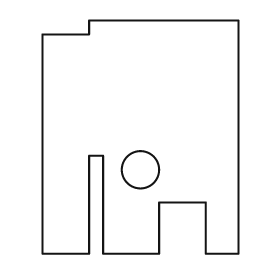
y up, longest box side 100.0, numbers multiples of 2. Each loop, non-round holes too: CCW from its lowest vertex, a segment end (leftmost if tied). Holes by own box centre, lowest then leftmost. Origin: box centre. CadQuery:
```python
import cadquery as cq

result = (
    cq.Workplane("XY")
    .moveTo(-42.0, -50.0)
    .lineTo(-22.0, -50.0)
    .lineTo(-22.0, -8.0)
    .lineTo(-16.0, -8.0)
    .lineTo(-16.0, -50.0)
    .lineTo(8.0, -50.0)
    .lineTo(8.0, -28.0)
    .lineTo(28.0, -28.0)
    .lineTo(28.0, -50.0)
    .lineTo(42.0, -50.0)
    .lineTo(42.0, 50.0)
    .lineTo(-22.0, 50.0)
    .lineTo(-22.0, 44.0)
    .lineTo(-42.0, 44.0)
    .close()
    .moveTo(0.0, -14.0)
    .circle(8.0)
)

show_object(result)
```